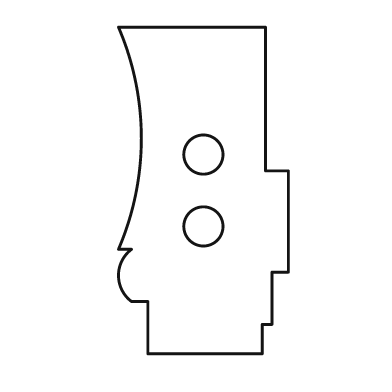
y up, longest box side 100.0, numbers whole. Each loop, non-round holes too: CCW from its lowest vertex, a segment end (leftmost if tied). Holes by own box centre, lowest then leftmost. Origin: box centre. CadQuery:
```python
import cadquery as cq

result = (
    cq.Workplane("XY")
    .moveTo(-17.0, -50.0)
    .lineTo(18.0, -50.0)
    .lineTo(18.0, -41.0)
    .lineTo(21.0, -41.0)
    .lineTo(21.0, -25.0)
    .lineTo(26.0, -25.0)
    .lineTo(26.0, 6.0)
    .lineTo(19.0, 6.0)
    .lineTo(19.0, 50.0)
    .lineTo(-26.0, 50.0)
    .threePointArc((-19.0, 16.0), (-26.0, -18.0))
    .lineTo(-22.0, -18.0)
    .threePointArc((-26.0, -26.0), (-22.0, -34.0))
    .lineTo(-17.0, -34.0)
    .close()
    .moveTo(0.0, -11.0)
    .circle(6.0)
    .moveTo(0.0, 11.0)
    .circle(6.0)
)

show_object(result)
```